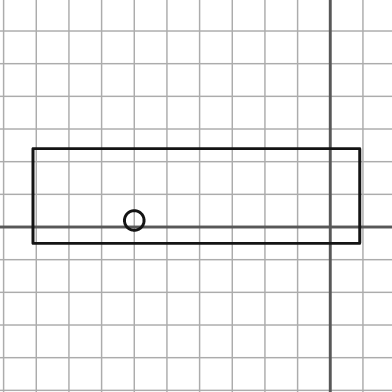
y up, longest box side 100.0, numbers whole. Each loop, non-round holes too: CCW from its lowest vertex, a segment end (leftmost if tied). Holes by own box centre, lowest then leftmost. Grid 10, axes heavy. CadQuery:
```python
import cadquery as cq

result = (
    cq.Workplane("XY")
    .moveTo(-91.0, -5.0)
    .lineTo(9.0, -5.0)
    .lineTo(9.0, 24.0)
    .lineTo(-91.0, 24.0)
    .close()
    .moveTo(-60.0, 2.0)
    .circle(3.0)
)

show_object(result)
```